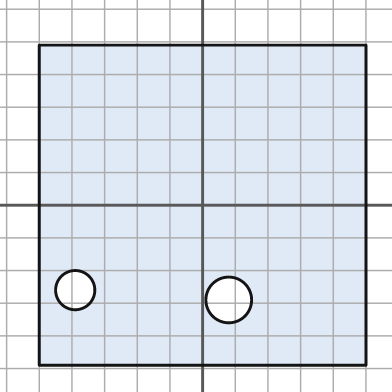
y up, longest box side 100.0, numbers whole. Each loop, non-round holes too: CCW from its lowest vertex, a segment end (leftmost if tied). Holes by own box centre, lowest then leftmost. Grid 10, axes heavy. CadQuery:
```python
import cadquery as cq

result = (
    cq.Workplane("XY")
    .moveTo(-50.0, -49.0)
    .lineTo(50.0, -49.0)
    .lineTo(50.0, 49.0)
    .lineTo(-50.0, 49.0)
    .close()
    .moveTo(8.0, -29.0)
    .circle(7.0)
    .moveTo(-39.0, -26.0)
    .circle(6.0)
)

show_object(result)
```